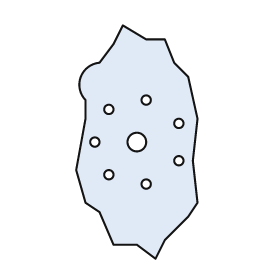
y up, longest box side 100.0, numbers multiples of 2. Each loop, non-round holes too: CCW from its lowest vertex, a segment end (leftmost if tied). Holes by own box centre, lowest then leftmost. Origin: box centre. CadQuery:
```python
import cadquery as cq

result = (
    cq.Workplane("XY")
    .moveTo(8.0, -50.0)
    .lineTo(12.0, -42.0)
    .lineTo(22.0, -32.0)
    .lineTo(26.0, -26.0)
    .lineTo(24.0, -8.0)
    .lineTo(26.0, 10.0)
    .lineTo(22.0, 28.0)
    .lineTo(16.0, 34.0)
    .lineTo(12.0, 44.0)
    .lineTo(4.0, 44.0)
    .lineTo(-6.0, 50.0)
    .lineTo(-10.0, 42.0)
    .lineTo(-16.0, 34.0)
    .threePointArc((-24.0, 28.0), (-22.0, 18.0))
    .lineTo(-22.0, 10.0)
    .lineTo(-26.0, -12.0)
    .lineTo(-22.0, -26.0)
    .lineTo(-16.0, -30.0)
    .lineTo(-10.0, -44.0)
    .lineTo(0.0, -44.0)
    .close()
    .moveTo(4.0, -18.0)
    .circle(2.0)
    .moveTo(-12.0, -14.0)
    .circle(2.0)
    .moveTo(18.0, -8.0)
    .circle(2.0)
    .moveTo(-18.0, 0.0)
    .circle(2.0)
    .moveTo(0.0, 0.0)
    .circle(4.0)
    .moveTo(18.0, 8.0)
    .circle(2.0)
    .moveTo(-12.0, 14.0)
    .circle(2.0)
    .moveTo(4.0, 18.0)
    .circle(2.0)
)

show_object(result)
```